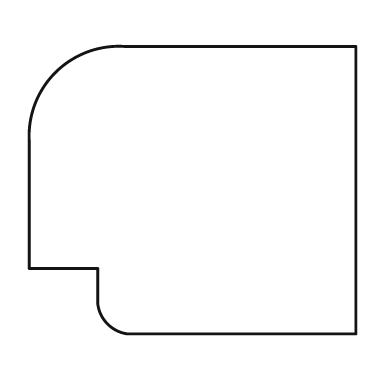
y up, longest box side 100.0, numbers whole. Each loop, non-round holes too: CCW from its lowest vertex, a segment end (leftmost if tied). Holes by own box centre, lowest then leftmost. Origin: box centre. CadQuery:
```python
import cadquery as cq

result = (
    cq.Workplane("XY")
    .moveTo(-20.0, -44.0)
    .lineTo(50.0, -44.0)
    .lineTo(50.0, 44.0)
    .lineTo(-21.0, 44.0)
    .threePointArc((-42.0, 36.0), (-50.0, 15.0))
    .lineTo(-50.0, -24.0)
    .lineTo(-29.0, -24.0)
    .lineTo(-29.0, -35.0)
    .threePointArc((-26.0, -41.0), (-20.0, -44.0))
    .close()
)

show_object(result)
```